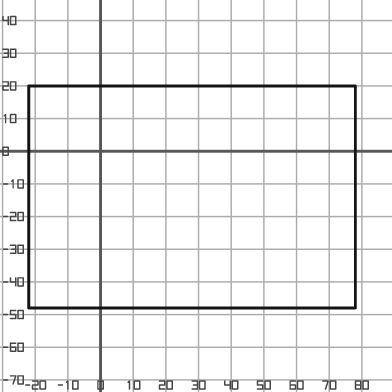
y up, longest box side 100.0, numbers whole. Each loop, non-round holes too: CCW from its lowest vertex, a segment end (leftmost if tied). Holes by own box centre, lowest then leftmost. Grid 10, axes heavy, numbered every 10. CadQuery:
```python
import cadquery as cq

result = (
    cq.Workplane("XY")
    .moveTo(-22.0, -48.0)
    .lineTo(78.0, -48.0)
    .lineTo(78.0, 20.0)
    .lineTo(-22.0, 20.0)
    .close()
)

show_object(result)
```